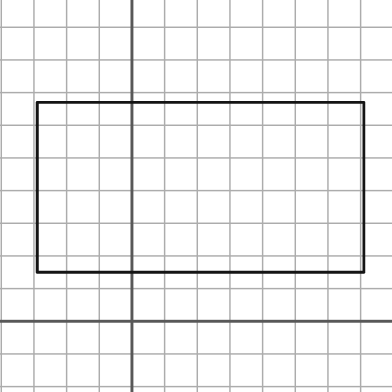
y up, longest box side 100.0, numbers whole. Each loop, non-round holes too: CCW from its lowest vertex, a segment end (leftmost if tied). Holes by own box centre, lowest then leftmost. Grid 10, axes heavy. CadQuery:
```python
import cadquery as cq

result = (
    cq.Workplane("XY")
    .moveTo(-29.0, 15.0)
    .lineTo(71.0, 15.0)
    .lineTo(71.0, 67.0)
    .lineTo(-29.0, 67.0)
    .close()
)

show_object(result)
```